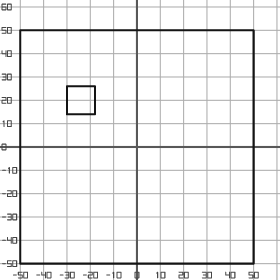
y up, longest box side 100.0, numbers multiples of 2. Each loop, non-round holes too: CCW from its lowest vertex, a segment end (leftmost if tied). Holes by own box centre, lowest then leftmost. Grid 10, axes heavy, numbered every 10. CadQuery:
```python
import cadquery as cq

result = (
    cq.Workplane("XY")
    .moveTo(-50.0, -50.0)
    .lineTo(50.0, -50.0)
    .lineTo(50.0, 50.0)
    .lineTo(-50.0, 50.0)
    .close()
    .moveTo(-30.0, 14.0)
    .lineTo(-18.0, 14.0)
    .lineTo(-18.0, 26.0)
    .lineTo(-30.0, 26.0)
    .close()
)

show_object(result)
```